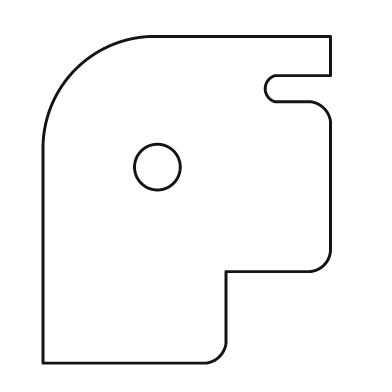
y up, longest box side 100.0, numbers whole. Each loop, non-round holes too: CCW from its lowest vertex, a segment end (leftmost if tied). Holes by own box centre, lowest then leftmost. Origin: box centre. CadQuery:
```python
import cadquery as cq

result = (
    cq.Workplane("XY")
    .moveTo(-44.0, -50.0)
    .lineTo(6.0, -50.0)
    .threePointArc((10.0, -48.0), (12.0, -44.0))
    .lineTo(12.0, -22.0)
    .lineTo(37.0, -22.0)
    .threePointArc((42.0, -20.0), (44.0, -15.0))
    .lineTo(44.0, 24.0)
    .threePointArc((42.0, 28.0), (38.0, 30.0))
    .lineTo(27.0, 30.0)
    .threePointArc((24.0, 34.0), (27.0, 38.0))
    .lineTo(44.0, 38.0)
    .lineTo(44.0, 50.0)
    .lineTo(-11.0, 50.0)
    .threePointArc((-34.0, 40.0), (-44.0, 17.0))
    .close()
    .moveTo(-9.0, 10.0)
    .circle(7.0)
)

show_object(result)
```